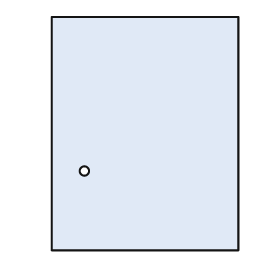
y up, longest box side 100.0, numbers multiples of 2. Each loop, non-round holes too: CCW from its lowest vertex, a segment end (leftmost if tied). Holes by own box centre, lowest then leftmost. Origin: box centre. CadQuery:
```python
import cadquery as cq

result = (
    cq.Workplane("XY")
    .moveTo(-40.0, -50.0)
    .lineTo(40.0, -50.0)
    .lineTo(40.0, 50.0)
    .lineTo(-40.0, 50.0)
    .close()
    .moveTo(-26.0, -16.0)
    .circle(2.0)
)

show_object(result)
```